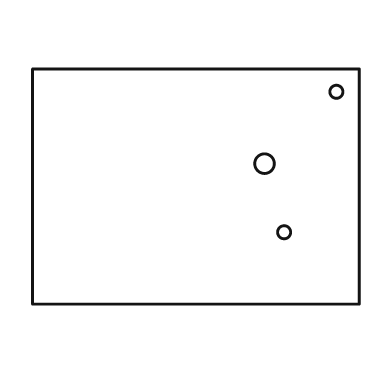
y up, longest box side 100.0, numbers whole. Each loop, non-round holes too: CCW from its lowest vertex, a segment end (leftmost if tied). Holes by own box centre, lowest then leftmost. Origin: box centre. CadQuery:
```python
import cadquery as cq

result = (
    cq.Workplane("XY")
    .moveTo(-50.0, -36.0)
    .lineTo(50.0, -36.0)
    .lineTo(50.0, 36.0)
    .lineTo(-50.0, 36.0)
    .close()
    .moveTo(27.0, -14.0)
    .circle(2.0)
    .moveTo(21.0, 7.0)
    .circle(3.0)
    .moveTo(43.0, 29.0)
    .circle(2.0)
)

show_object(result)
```